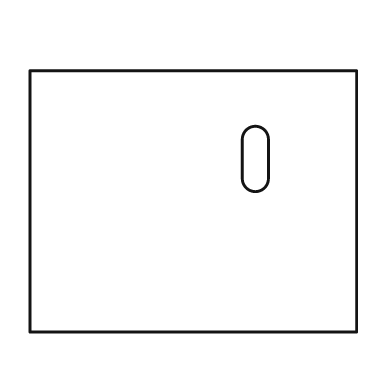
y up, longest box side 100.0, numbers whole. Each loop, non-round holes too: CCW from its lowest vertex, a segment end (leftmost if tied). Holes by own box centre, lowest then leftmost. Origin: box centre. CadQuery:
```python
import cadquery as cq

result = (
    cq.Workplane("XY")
    .moveTo(-50.0, -40.0)
    .lineTo(50.0, -40.0)
    .lineTo(50.0, 40.0)
    .lineTo(-50.0, 40.0)
    .close()
    .moveTo(15.0, 7.0)
    .threePointArc((19.0, 3.0), (23.0, 7.0))
    .lineTo(23.0, 19.0)
    .threePointArc((19.0, 23.0), (15.0, 19.0))
    .close()
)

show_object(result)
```